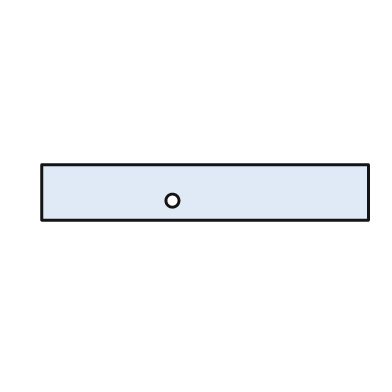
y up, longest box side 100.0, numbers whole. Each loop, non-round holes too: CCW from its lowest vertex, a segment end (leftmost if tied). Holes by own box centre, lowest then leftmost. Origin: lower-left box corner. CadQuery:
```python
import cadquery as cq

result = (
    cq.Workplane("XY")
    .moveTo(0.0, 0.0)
    .lineTo(100.0, 0.0)
    .lineTo(100.0, 17.0)
    .lineTo(0.0, 17.0)
    .close()
    .moveTo(40.0, 6.0)
    .circle(2.0)
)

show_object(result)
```